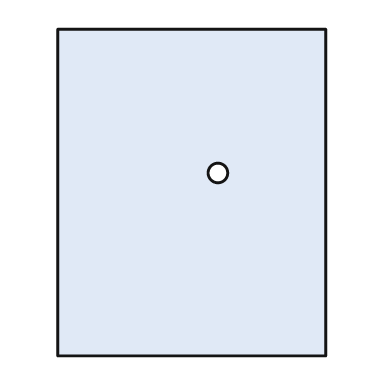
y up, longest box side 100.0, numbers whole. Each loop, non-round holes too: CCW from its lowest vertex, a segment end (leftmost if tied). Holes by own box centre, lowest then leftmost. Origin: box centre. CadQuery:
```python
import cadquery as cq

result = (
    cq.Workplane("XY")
    .moveTo(-41.0, -50.0)
    .lineTo(41.0, -50.0)
    .lineTo(41.0, 50.0)
    .lineTo(-41.0, 50.0)
    .close()
    .moveTo(8.0, 6.0)
    .circle(3.0)
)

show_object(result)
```